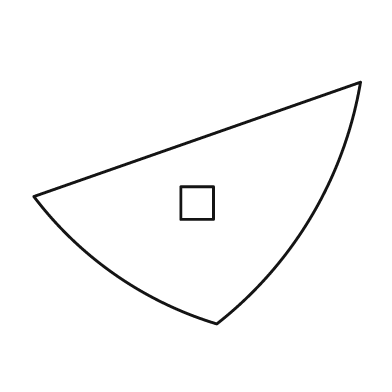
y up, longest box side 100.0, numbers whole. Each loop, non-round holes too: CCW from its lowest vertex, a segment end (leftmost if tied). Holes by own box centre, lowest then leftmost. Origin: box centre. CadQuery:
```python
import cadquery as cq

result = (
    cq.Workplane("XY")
    .moveTo(6.0, -37.0)
    .threePointArc((35.0, -4.0), (50.0, 37.0))
    .lineTo(-50.0, 2.0)
    .threePointArc((-25.0, -22.0), (6.0, -37.0))
    .close()
    .moveTo(-5.0, -5.0)
    .lineTo(5.0, -5.0)
    .lineTo(5.0, 5.0)
    .lineTo(-5.0, 5.0)
    .close()
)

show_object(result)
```